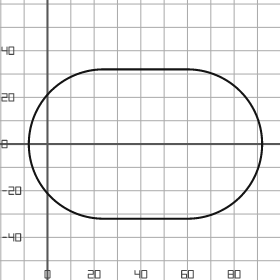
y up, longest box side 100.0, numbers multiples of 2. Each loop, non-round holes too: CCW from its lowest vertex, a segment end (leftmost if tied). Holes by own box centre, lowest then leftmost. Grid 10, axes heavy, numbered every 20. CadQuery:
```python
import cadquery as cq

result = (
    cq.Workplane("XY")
    .moveTo(24.0, -32.0)
    .lineTo(60.0, -32.0)
    .threePointArc((92.0, 0.0), (60.0, 32.0))
    .lineTo(24.0, 32.0)
    .threePointArc((-8.0, 0.0), (24.0, -32.0))
    .close()
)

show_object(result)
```